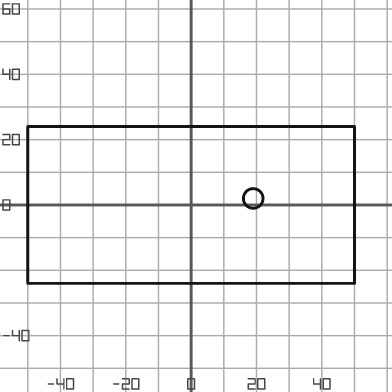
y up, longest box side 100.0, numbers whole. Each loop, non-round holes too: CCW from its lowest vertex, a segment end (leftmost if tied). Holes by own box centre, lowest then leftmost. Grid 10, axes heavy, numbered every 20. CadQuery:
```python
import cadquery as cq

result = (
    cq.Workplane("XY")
    .moveTo(-50.0, -24.0)
    .lineTo(50.0, -24.0)
    .lineTo(50.0, 24.0)
    .lineTo(-50.0, 24.0)
    .close()
    .moveTo(19.0, 2.0)
    .circle(3.0)
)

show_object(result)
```